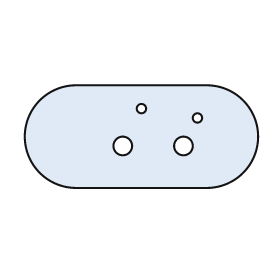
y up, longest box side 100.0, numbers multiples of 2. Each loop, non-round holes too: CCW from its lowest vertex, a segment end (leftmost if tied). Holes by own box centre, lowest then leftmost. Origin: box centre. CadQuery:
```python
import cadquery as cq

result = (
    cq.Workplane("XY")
    .moveTo(-28.0, -22.0)
    .lineTo(28.0, -22.0)
    .threePointArc((50.0, 0.0), (28.0, 22.0))
    .lineTo(-28.0, 22.0)
    .threePointArc((-50.0, 0.0), (-28.0, -22.0))
    .close()
    .moveTo(-8.0, -4.0)
    .circle(4.0)
    .moveTo(18.0, -4.0)
    .circle(4.0)
    .moveTo(24.0, 8.0)
    .circle(2.0)
    .moveTo(0.0, 12.0)
    .circle(2.0)
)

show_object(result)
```